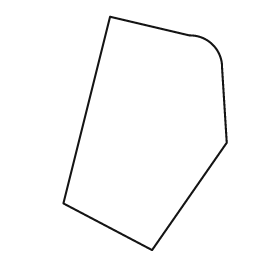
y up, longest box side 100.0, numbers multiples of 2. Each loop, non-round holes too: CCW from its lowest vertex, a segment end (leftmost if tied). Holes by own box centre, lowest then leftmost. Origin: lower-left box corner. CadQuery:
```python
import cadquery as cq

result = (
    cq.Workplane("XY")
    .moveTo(38.0, 0.0)
    .lineTo(70.0, 46.0)
    .lineTo(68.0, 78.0)
    .threePointArc((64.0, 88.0), (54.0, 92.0))
    .lineTo(20.0, 100.0)
    .lineTo(0.0, 20.0)
    .close()
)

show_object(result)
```